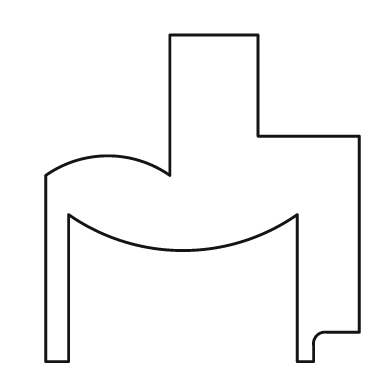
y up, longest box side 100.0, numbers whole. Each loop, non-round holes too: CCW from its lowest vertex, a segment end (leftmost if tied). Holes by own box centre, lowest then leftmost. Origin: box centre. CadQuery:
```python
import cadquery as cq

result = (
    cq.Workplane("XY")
    .moveTo(-48.0, -50.0)
    .lineTo(-41.0, -50.0)
    .lineTo(-41.0, -5.0)
    .threePointArc((-6.0, -16.0), (29.0, -5.0))
    .lineTo(29.0, -50.0)
    .lineTo(34.0, -50.0)
    .lineTo(34.0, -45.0)
    .threePointArc((35.0, -42.0), (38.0, -41.0))
    .lineTo(48.0, -41.0)
    .lineTo(48.0, 19.0)
    .lineTo(17.0, 19.0)
    .lineTo(17.0, 50.0)
    .lineTo(-10.0, 50.0)
    .lineTo(-10.0, 7.0)
    .threePointArc((-29.0, 13.0), (-48.0, 7.0))
    .close()
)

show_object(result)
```